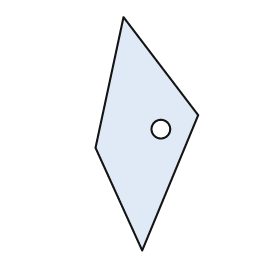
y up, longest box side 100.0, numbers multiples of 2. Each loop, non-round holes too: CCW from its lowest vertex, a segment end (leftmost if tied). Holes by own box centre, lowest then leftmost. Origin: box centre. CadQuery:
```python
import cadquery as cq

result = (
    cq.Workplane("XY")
    .moveTo(-2.0, -50.0)
    .lineTo(22.0, 8.0)
    .lineTo(-10.0, 50.0)
    .lineTo(-22.0, -6.0)
    .close()
    .moveTo(6.0, 2.0)
    .circle(4.0)
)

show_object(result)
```